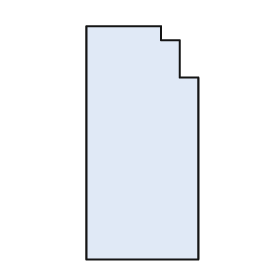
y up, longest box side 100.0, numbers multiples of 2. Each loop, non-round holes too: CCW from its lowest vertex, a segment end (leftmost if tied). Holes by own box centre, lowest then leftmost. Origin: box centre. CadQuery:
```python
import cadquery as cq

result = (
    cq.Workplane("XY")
    .moveTo(-24.0, -50.0)
    .lineTo(24.0, -50.0)
    .lineTo(24.0, 28.0)
    .lineTo(16.0, 28.0)
    .lineTo(16.0, 44.0)
    .lineTo(8.0, 44.0)
    .lineTo(8.0, 50.0)
    .lineTo(-24.0, 50.0)
    .close()
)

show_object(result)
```